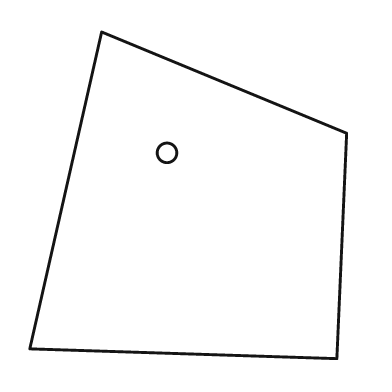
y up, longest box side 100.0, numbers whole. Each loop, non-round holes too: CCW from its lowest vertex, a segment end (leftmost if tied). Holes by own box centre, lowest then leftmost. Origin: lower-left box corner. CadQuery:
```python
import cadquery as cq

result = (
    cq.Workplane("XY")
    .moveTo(94.0, 0.0)
    .lineTo(97.0, 69.0)
    .lineTo(22.0, 100.0)
    .lineTo(0.0, 3.0)
    .close()
    .moveTo(42.0, 63.0)
    .circle(3.0)
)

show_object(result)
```